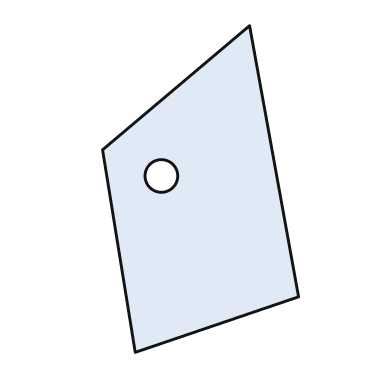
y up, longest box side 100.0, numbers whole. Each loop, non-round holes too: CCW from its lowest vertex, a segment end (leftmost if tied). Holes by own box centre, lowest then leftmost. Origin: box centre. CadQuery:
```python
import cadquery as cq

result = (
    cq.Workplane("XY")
    .moveTo(-20.0, -50.0)
    .lineTo(30.0, -33.0)
    .lineTo(15.0, 50.0)
    .lineTo(-30.0, 12.0)
    .close()
    .moveTo(-12.0, 4.0)
    .circle(5.0)
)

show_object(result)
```